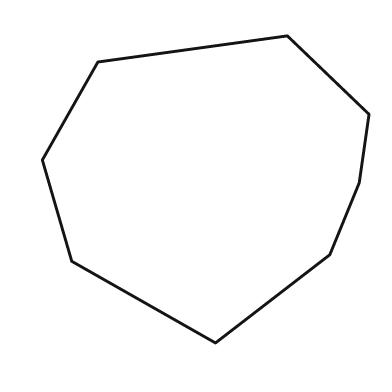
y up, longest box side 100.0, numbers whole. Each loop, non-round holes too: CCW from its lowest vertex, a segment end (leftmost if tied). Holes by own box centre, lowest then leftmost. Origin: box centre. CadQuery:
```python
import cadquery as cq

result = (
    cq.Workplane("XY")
    .moveTo(3.0, -47.0)
    .lineTo(38.0, -20.0)
    .lineTo(47.0, 2.0)
    .lineTo(50.0, 23.0)
    .lineTo(25.0, 47.0)
    .lineTo(-33.0, 39.0)
    .lineTo(-50.0, 9.0)
    .lineTo(-41.0, -22.0)
    .close()
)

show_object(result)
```